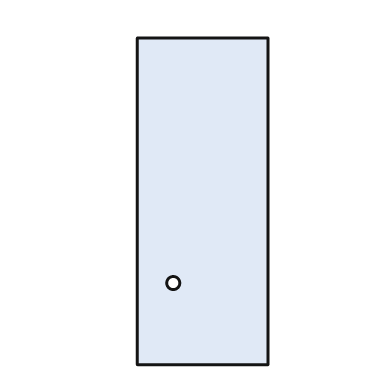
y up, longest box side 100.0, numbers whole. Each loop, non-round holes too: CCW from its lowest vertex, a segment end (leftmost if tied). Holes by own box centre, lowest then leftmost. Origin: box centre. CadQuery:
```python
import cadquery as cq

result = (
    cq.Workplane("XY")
    .moveTo(-20.0, -50.0)
    .lineTo(20.0, -50.0)
    .lineTo(20.0, 50.0)
    .lineTo(-20.0, 50.0)
    .close()
    .moveTo(-9.0, -25.0)
    .circle(2.0)
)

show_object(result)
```